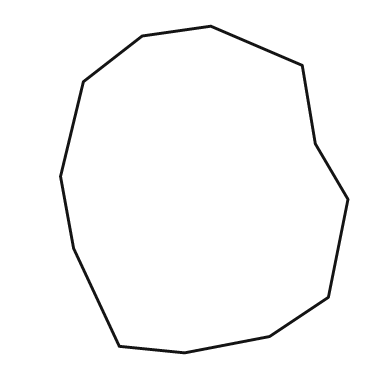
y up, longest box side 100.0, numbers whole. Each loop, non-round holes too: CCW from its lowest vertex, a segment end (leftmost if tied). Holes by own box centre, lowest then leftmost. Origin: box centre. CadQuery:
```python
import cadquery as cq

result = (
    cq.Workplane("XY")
    .moveTo(-6.0, -50.0)
    .lineTo(20.0, -45.0)
    .lineTo(38.0, -33.0)
    .lineTo(44.0, -3.0)
    .lineTo(34.0, 14.0)
    .lineTo(30.0, 38.0)
    .lineTo(2.0, 50.0)
    .lineTo(-19.0, 47.0)
    .lineTo(-37.0, 33.0)
    .lineTo(-44.0, 4.0)
    .lineTo(-40.0, -18.0)
    .lineTo(-26.0, -48.0)
    .close()
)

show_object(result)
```